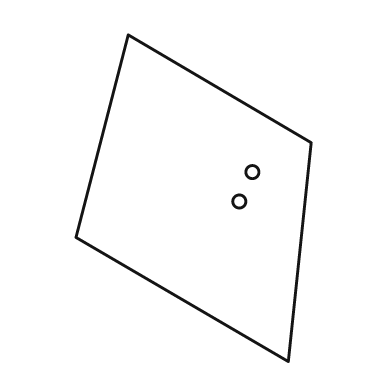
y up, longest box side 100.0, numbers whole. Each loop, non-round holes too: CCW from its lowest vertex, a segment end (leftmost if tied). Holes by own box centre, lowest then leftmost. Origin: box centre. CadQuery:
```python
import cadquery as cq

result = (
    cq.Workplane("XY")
    .moveTo(29.0, -50.0)
    .lineTo(36.0, 17.0)
    .lineTo(-20.0, 50.0)
    .lineTo(-36.0, -12.0)
    .close()
    .moveTo(14.0, -1.0)
    .circle(2.0)
    .moveTo(18.0, 8.0)
    .circle(2.0)
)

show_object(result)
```